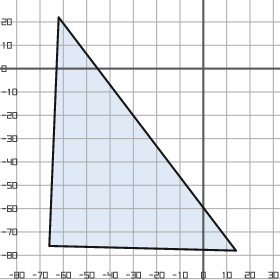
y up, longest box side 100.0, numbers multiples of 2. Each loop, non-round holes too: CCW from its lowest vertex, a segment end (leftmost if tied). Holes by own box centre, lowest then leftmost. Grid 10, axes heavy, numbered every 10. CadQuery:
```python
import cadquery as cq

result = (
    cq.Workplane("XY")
    .moveTo(14.0, -78.0)
    .lineTo(-62.0, 22.0)
    .lineTo(-66.0, -76.0)
    .close()
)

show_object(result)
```